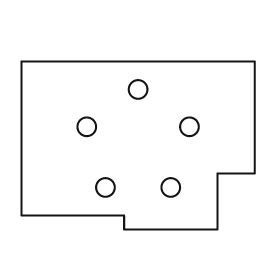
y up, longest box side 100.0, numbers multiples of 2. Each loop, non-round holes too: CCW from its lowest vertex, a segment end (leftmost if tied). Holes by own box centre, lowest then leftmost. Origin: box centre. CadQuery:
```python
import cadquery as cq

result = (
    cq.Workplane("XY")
    .moveTo(-6.0, -36.0)
    .lineTo(34.0, -36.0)
    .lineTo(34.0, -12.0)
    .lineTo(50.0, -12.0)
    .lineTo(50.0, 36.0)
    .lineTo(-50.0, 36.0)
    .lineTo(-50.0, -30.0)
    .lineTo(-6.0, -30.0)
    .close()
    .moveTo(-14.0, -18.0)
    .circle(4.0)
    .moveTo(14.0, -18.0)
    .circle(4.0)
    .moveTo(-22.0, 8.0)
    .circle(4.0)
    .moveTo(22.0, 8.0)
    .circle(4.0)
    .moveTo(0.0, 24.0)
    .circle(4.0)
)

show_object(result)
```